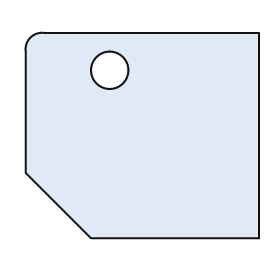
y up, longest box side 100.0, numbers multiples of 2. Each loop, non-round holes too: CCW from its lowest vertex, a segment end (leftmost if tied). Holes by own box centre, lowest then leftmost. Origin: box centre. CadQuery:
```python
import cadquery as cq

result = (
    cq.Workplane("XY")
    .moveTo(-22.0, -44.0)
    .lineTo(50.0, -44.0)
    .lineTo(50.0, 44.0)
    .lineTo(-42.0, 44.0)
    .threePointArc((-48.0, 42.0), (-50.0, 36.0))
    .lineTo(-50.0, -16.0)
    .close()
    .moveTo(-14.0, 28.0)
    .circle(8.0)
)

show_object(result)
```